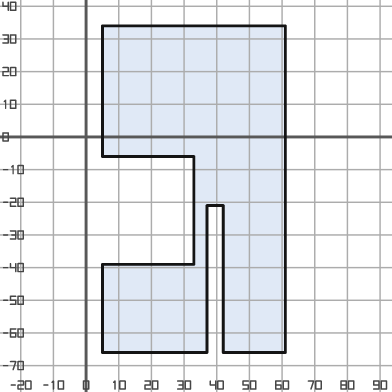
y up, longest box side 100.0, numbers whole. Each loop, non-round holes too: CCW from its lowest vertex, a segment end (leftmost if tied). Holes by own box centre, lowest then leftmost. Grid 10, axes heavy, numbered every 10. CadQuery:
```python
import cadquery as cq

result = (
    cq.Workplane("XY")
    .moveTo(5.0, -66.0)
    .lineTo(37.0, -66.0)
    .lineTo(37.0, -21.0)
    .lineTo(42.0, -21.0)
    .lineTo(42.0, -66.0)
    .lineTo(61.0, -66.0)
    .lineTo(61.0, 34.0)
    .lineTo(5.0, 34.0)
    .lineTo(5.0, -6.0)
    .lineTo(33.0, -6.0)
    .lineTo(33.0, -39.0)
    .lineTo(5.0, -39.0)
    .close()
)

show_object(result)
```